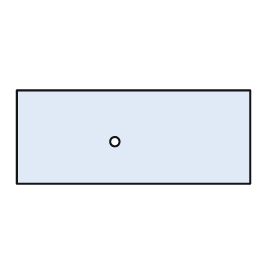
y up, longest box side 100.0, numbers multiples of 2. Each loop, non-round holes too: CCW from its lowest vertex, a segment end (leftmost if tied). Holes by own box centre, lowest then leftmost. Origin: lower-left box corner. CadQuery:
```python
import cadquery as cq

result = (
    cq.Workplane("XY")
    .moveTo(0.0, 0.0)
    .lineTo(100.0, 0.0)
    .lineTo(100.0, 40.0)
    .lineTo(0.0, 40.0)
    .close()
    .moveTo(42.0, 18.0)
    .circle(2.0)
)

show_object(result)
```